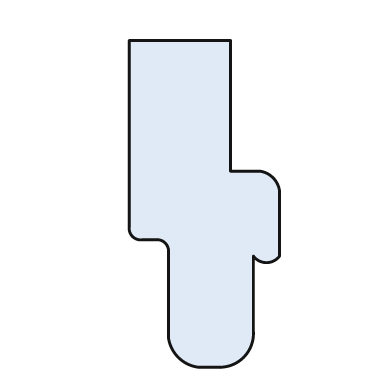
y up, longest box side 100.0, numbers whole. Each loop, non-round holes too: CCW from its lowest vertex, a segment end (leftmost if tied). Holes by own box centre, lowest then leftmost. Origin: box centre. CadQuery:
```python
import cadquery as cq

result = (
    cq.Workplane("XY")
    .moveTo(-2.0, -50.0)
    .lineTo(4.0, -50.0)
    .threePointArc((12.0, -47.0), (15.0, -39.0))
    .lineTo(15.0, -16.0)
    .threePointArc((19.0, -18.0), (23.0, -16.0))
    .lineTo(23.0, 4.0)
    .threePointArc((21.0, 8.0), (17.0, 10.0))
    .lineTo(8.0, 10.0)
    .lineTo(8.0, 50.0)
    .lineTo(-23.0, 50.0)
    .lineTo(-23.0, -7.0)
    .threePointArc((-22.0, -10.0), (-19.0, -11.0))
    .lineTo(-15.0, -11.0)
    .threePointArc((-12.0, -12.0), (-11.0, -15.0))
    .lineTo(-11.0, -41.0)
    .threePointArc((-8.0, -47.0), (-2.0, -50.0))
    .close()
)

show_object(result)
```